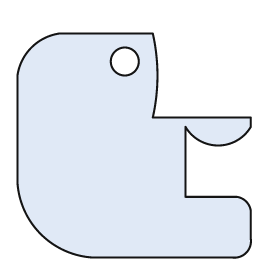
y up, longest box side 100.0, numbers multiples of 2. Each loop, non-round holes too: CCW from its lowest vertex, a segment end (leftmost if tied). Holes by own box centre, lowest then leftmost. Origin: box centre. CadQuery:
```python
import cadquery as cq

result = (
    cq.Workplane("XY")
    .moveTo(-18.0, -48.0)
    .lineTo(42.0, -48.0)
    .threePointArc((48.0, -46.0), (50.0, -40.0))
    .lineTo(50.0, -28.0)
    .threePointArc((48.0, -24.0), (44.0, -22.0))
    .lineTo(22.0, -22.0)
    .lineTo(22.0, 8.0)
    .threePointArc((36.0, 0.0), (50.0, 8.0))
    .lineTo(50.0, 12.0)
    .lineTo(8.0, 12.0)
    .threePointArc((10.0, 30.0), (8.0, 48.0))
    .lineTo(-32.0, 48.0)
    .threePointArc((-44.0, 42.0), (-50.0, 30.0))
    .lineTo(-50.0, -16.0)
    .threePointArc((-40.0, -38.0), (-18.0, -48.0))
    .close()
    .moveTo(-4.0, 36.0)
    .circle(6.0)
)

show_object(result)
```